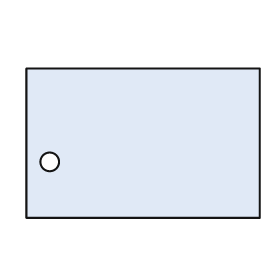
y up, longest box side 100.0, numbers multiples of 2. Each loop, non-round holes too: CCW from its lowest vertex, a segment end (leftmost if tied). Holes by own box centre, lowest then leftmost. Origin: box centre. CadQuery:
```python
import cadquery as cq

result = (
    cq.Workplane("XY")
    .moveTo(-50.0, -32.0)
    .lineTo(50.0, -32.0)
    .lineTo(50.0, 32.0)
    .lineTo(-50.0, 32.0)
    .close()
    .moveTo(-40.0, -8.0)
    .circle(4.0)
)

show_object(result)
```